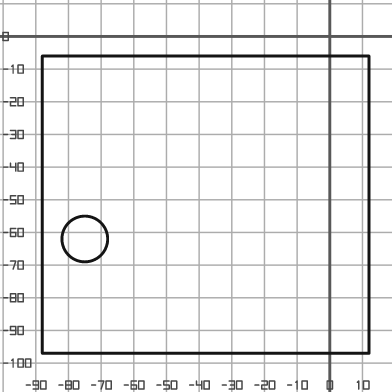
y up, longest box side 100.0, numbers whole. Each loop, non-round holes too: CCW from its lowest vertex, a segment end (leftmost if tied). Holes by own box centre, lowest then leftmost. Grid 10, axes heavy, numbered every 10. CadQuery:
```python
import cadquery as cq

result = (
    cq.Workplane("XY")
    .moveTo(-88.0, -97.0)
    .lineTo(12.0, -97.0)
    .lineTo(12.0, -6.0)
    .lineTo(-88.0, -6.0)
    .close()
    .moveTo(-75.0, -62.0)
    .circle(7.0)
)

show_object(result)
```